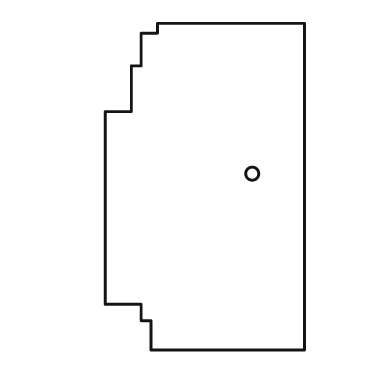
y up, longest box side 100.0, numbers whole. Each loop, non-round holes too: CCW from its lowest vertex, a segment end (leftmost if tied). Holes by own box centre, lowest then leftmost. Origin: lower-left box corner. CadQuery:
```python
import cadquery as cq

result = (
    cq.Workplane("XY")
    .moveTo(14.0, 0.0)
    .lineTo(61.0, 0.0)
    .lineTo(61.0, 100.0)
    .lineTo(16.0, 100.0)
    .lineTo(16.0, 97.0)
    .lineTo(11.0, 97.0)
    .lineTo(11.0, 87.0)
    .lineTo(8.0, 87.0)
    .lineTo(8.0, 73.0)
    .lineTo(0.0, 73.0)
    .lineTo(0.0, 14.0)
    .lineTo(11.0, 14.0)
    .lineTo(11.0, 9.0)
    .lineTo(14.0, 9.0)
    .close()
    .moveTo(45.0, 54.0)
    .circle(2.0)
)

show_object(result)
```